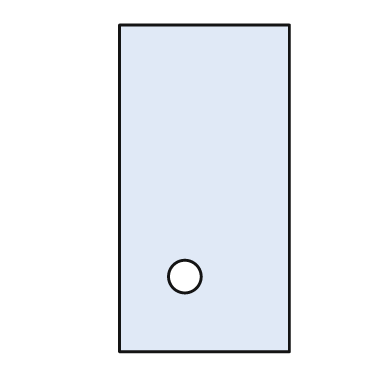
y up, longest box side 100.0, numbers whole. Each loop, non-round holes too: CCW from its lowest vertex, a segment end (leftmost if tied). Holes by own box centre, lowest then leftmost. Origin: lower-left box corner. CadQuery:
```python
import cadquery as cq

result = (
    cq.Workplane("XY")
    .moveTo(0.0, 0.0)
    .lineTo(52.0, 0.0)
    .lineTo(52.0, 100.0)
    .lineTo(0.0, 100.0)
    .close()
    .moveTo(20.0, 23.0)
    .circle(5.0)
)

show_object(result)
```